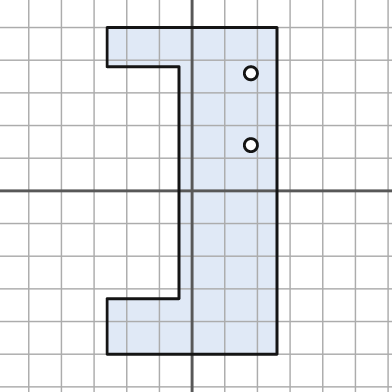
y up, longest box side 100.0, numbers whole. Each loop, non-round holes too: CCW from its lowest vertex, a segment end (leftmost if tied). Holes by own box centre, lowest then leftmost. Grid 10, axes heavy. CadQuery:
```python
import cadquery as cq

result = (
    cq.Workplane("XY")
    .moveTo(-26.0, -50.0)
    .lineTo(26.0, -50.0)
    .lineTo(26.0, 50.0)
    .lineTo(-26.0, 50.0)
    .lineTo(-26.0, 38.0)
    .lineTo(-4.0, 38.0)
    .lineTo(-4.0, -33.0)
    .lineTo(-26.0, -33.0)
    .close()
    .moveTo(18.0, 14.0)
    .circle(2.0)
    .moveTo(18.0, 36.0)
    .circle(2.0)
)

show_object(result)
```